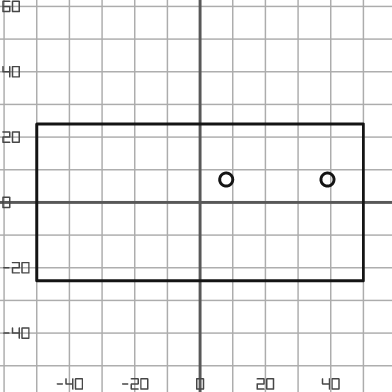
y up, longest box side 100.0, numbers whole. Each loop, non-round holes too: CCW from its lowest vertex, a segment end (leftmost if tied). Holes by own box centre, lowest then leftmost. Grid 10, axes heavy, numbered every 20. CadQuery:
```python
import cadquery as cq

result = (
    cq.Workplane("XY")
    .moveTo(-50.0, -24.0)
    .lineTo(50.0, -24.0)
    .lineTo(50.0, 24.0)
    .lineTo(-50.0, 24.0)
    .close()
    .moveTo(8.0, 7.0)
    .circle(2.0)
    .moveTo(39.0, 7.0)
    .circle(2.0)
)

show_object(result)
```